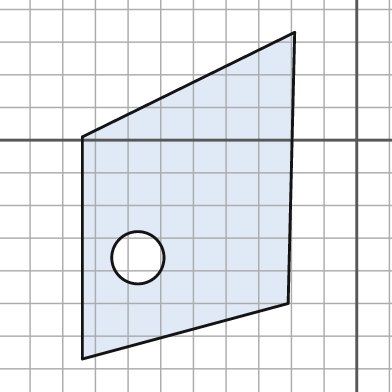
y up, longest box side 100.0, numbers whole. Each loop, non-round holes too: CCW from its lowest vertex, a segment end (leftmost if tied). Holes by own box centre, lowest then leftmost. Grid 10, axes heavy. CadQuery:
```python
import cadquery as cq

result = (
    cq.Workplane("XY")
    .moveTo(-84.0, -67.0)
    .lineTo(-21.0, -50.0)
    .lineTo(-19.0, 33.0)
    .lineTo(-84.0, 1.0)
    .close()
    .moveTo(-67.0, -36.0)
    .circle(8.0)
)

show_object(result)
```